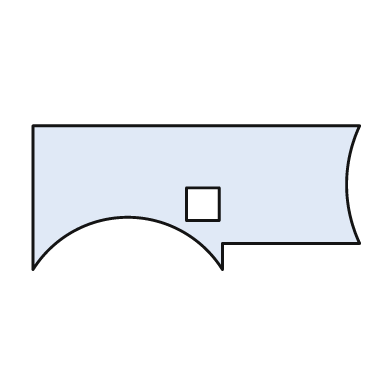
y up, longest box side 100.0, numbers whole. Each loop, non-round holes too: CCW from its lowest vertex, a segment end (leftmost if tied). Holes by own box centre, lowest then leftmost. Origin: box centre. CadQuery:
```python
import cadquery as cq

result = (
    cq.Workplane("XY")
    .moveTo(-50.0, -22.0)
    .threePointArc((-21.0, -6.0), (8.0, -22.0))
    .lineTo(8.0, -14.0)
    .lineTo(50.0, -14.0)
    .threePointArc((46.0, 4.0), (50.0, 22.0))
    .lineTo(-50.0, 22.0)
    .close()
    .moveTo(-3.0, -7.0)
    .lineTo(7.0, -7.0)
    .lineTo(7.0, 3.0)
    .lineTo(-3.0, 3.0)
    .close()
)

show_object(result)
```